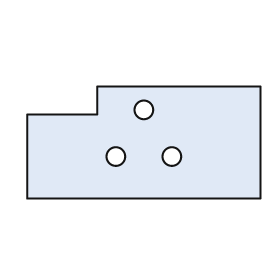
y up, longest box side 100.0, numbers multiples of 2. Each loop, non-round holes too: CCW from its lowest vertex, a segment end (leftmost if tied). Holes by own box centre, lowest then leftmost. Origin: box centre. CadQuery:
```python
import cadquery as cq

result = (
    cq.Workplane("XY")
    .moveTo(-50.0, -24.0)
    .lineTo(50.0, -24.0)
    .lineTo(50.0, 24.0)
    .lineTo(-20.0, 24.0)
    .lineTo(-20.0, 12.0)
    .lineTo(-50.0, 12.0)
    .close()
    .moveTo(-12.0, -6.0)
    .circle(4.0)
    .moveTo(12.0, -6.0)
    .circle(4.0)
    .moveTo(0.0, 14.0)
    .circle(4.0)
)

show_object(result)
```